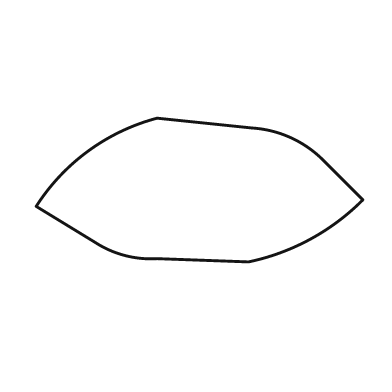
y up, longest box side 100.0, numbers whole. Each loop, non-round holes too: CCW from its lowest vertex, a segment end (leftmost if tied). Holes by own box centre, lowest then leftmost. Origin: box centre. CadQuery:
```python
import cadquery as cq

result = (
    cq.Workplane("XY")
    .moveTo(15.0, -22.0)
    .threePointArc((34.0, -15.0), (50.0, -3.0))
    .lineTo(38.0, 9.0)
    .threePointArc((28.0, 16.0), (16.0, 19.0))
    .lineTo(-13.0, 22.0)
    .threePointArc((-34.0, 12.0), (-50.0, -5.0))
    .lineTo(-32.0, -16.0)
    .threePointArc((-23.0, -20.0), (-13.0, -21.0))
    .close()
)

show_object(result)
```